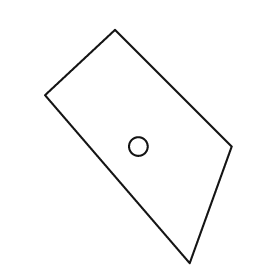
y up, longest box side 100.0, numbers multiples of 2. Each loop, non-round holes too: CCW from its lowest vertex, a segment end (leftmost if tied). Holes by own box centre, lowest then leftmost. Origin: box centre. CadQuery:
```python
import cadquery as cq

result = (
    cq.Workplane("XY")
    .moveTo(22.0, -50.0)
    .lineTo(40.0, 0.0)
    .lineTo(-10.0, 50.0)
    .lineTo(-40.0, 22.0)
    .close()
    .moveTo(0.0, 0.0)
    .circle(4.0)
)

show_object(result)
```